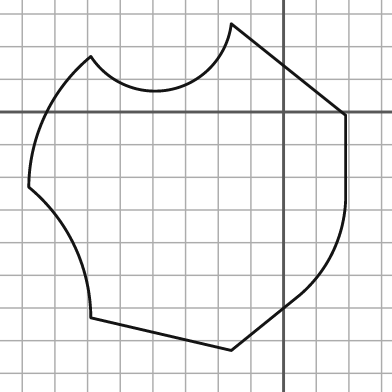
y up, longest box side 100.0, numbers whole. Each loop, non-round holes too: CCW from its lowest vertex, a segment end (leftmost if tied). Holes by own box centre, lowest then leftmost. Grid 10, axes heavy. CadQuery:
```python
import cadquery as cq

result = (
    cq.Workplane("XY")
    .moveTo(-16.0, -73.0)
    .lineTo(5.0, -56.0)
    .threePointArc((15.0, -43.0), (19.0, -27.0))
    .lineTo(19.0, -1.0)
    .lineTo(-16.0, 27.0)
    .threePointArc((-34.0, 7.0), (-59.0, 17.0))
    .threePointArc((-73.0, -1.0), (-78.0, -23.0))
    .threePointArc((-64.0, -41.0), (-59.0, -63.0))
    .close()
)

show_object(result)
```